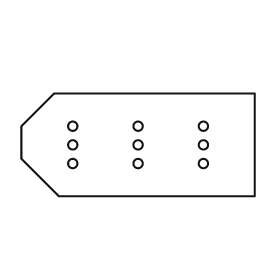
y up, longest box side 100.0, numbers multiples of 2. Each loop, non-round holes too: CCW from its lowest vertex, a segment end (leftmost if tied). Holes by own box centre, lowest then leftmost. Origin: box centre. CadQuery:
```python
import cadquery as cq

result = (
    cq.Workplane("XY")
    .moveTo(-34.0, -22.0)
    .lineTo(50.0, -22.0)
    .lineTo(50.0, 22.0)
    .lineTo(-36.0, 22.0)
    .lineTo(-50.0, 8.0)
    .lineTo(-50.0, -6.0)
    .close()
    .moveTo(-28.0, -8.0)
    .circle(2.0)
    .moveTo(0.0, -8.0)
    .circle(2.0)
    .moveTo(28.0, -8.0)
    .circle(2.0)
    .moveTo(-28.0, 0.0)
    .circle(2.0)
    .moveTo(0.0, 0.0)
    .circle(2.0)
    .moveTo(28.0, 0.0)
    .circle(2.0)
    .moveTo(-28.0, 8.0)
    .circle(2.0)
    .moveTo(0.0, 8.0)
    .circle(2.0)
    .moveTo(28.0, 8.0)
    .circle(2.0)
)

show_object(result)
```